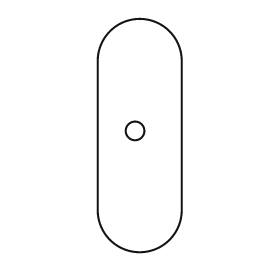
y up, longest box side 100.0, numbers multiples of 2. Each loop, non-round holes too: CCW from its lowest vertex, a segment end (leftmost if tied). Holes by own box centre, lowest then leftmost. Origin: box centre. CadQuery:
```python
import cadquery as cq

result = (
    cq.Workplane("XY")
    .moveTo(-18.0, -32.0)
    .threePointArc((0.0, -50.0), (18.0, -32.0))
    .lineTo(18.0, 32.0)
    .threePointArc((0.0, 50.0), (-18.0, 32.0))
    .close()
    .moveTo(-2.0, 2.0)
    .circle(4.0)
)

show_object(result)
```